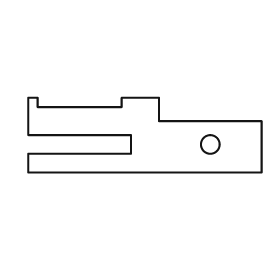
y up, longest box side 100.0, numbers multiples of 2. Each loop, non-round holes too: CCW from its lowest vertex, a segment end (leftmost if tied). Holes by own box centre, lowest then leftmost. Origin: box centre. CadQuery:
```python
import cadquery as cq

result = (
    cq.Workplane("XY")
    .moveTo(-50.0, -16.0)
    .lineTo(50.0, -16.0)
    .lineTo(50.0, 6.0)
    .lineTo(6.0, 6.0)
    .lineTo(6.0, 16.0)
    .lineTo(-10.0, 16.0)
    .lineTo(-10.0, 12.0)
    .lineTo(-46.0, 12.0)
    .lineTo(-46.0, 16.0)
    .lineTo(-50.0, 16.0)
    .lineTo(-50.0, 0.0)
    .lineTo(-6.0, 0.0)
    .lineTo(-6.0, -8.0)
    .lineTo(-50.0, -8.0)
    .close()
    .moveTo(28.0, -4.0)
    .circle(4.0)
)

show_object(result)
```